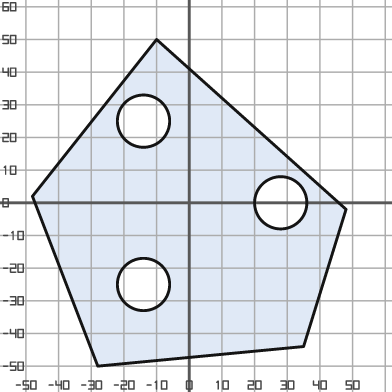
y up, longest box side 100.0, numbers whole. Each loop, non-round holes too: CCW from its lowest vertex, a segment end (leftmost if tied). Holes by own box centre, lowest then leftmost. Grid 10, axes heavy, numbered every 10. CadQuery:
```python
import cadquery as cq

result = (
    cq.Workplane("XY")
    .moveTo(-28.0, -50.0)
    .lineTo(35.0, -44.0)
    .lineTo(48.0, -2.0)
    .lineTo(-10.0, 50.0)
    .lineTo(-48.0, 2.0)
    .close()
    .moveTo(-14.0, -25.0)
    .circle(8.0)
    .moveTo(28.0, 0.0)
    .circle(8.0)
    .moveTo(-14.0, 25.0)
    .circle(8.0)
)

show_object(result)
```